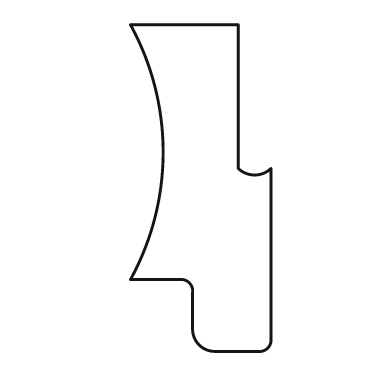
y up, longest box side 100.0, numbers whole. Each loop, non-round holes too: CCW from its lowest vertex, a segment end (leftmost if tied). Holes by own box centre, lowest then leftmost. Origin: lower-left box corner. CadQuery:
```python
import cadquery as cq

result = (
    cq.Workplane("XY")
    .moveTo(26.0, 0.0)
    .lineTo(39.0, 0.0)
    .threePointArc((42.0, 1.0), (43.0, 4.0))
    .lineTo(43.0, 56.0)
    .threePointArc((38.0, 54.0), (33.0, 56.0))
    .lineTo(33.0, 100.0)
    .lineTo(0.0, 100.0)
    .threePointArc((10.0, 61.0), (0.0, 22.0))
    .lineTo(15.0, 22.0)
    .threePointArc((18.0, 21.0), (19.0, 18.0))
    .lineTo(19.0, 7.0)
    .threePointArc((21.0, 2.0), (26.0, 0.0))
    .close()
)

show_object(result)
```